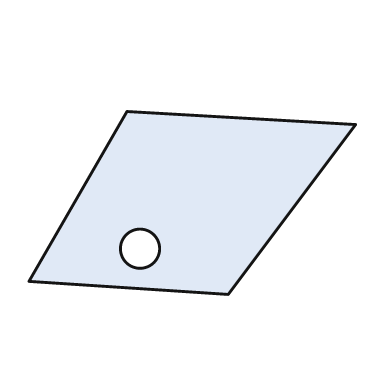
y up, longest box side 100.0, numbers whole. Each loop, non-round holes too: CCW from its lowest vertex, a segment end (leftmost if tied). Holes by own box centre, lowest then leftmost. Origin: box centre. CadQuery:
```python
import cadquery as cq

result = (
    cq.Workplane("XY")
    .moveTo(11.0, -28.0)
    .lineTo(50.0, 24.0)
    .lineTo(-20.0, 28.0)
    .lineTo(-50.0, -24.0)
    .close()
    .moveTo(-16.0, -14.0)
    .circle(6.0)
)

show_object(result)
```